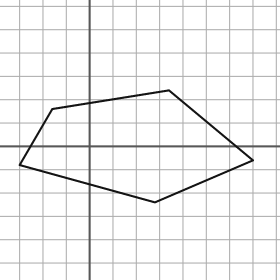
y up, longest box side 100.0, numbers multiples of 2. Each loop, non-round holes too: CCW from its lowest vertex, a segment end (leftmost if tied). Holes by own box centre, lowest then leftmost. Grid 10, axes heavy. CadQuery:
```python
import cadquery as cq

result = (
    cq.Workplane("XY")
    .moveTo(28.0, -24.0)
    .lineTo(70.0, -6.0)
    .lineTo(34.0, 24.0)
    .lineTo(-16.0, 16.0)
    .lineTo(-30.0, -8.0)
    .close()
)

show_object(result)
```